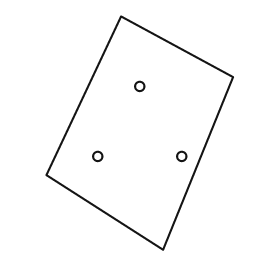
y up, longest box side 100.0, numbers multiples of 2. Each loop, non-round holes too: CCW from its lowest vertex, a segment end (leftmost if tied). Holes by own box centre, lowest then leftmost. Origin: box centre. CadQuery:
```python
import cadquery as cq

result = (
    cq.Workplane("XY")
    .moveTo(10.0, -50.0)
    .lineTo(40.0, 24.0)
    .lineTo(-8.0, 50.0)
    .lineTo(-40.0, -18.0)
    .close()
    .moveTo(-18.0, -10.0)
    .circle(2.0)
    .moveTo(18.0, -10.0)
    .circle(2.0)
    .moveTo(0.0, 20.0)
    .circle(2.0)
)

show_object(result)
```